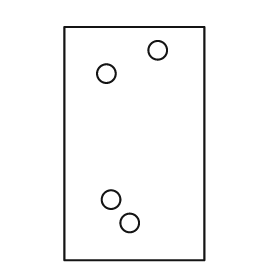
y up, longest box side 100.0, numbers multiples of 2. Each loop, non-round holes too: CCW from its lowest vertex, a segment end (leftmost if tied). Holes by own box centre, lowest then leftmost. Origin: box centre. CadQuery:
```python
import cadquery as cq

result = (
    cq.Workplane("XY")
    .moveTo(-30.0, -50.0)
    .lineTo(30.0, -50.0)
    .lineTo(30.0, 50.0)
    .lineTo(-30.0, 50.0)
    .close()
    .moveTo(-2.0, -34.0)
    .circle(4.0)
    .moveTo(-10.0, -24.0)
    .circle(4.0)
    .moveTo(-12.0, 30.0)
    .circle(4.0)
    .moveTo(10.0, 40.0)
    .circle(4.0)
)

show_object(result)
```